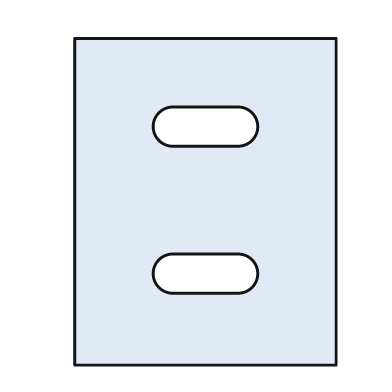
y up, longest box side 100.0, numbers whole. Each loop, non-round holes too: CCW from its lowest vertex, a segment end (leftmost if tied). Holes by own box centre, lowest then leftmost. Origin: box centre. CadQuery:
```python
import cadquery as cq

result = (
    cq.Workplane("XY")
    .moveTo(-40.0, -50.0)
    .lineTo(40.0, -50.0)
    .lineTo(40.0, 50.0)
    .lineTo(-40.0, 50.0)
    .close()
    .moveTo(-10.0, -28.0)
    .lineTo(10.0, -28.0)
    .threePointArc((16.0, -22.0), (10.0, -16.0))
    .lineTo(-10.0, -16.0)
    .threePointArc((-16.0, -22.0), (-10.0, -28.0))
    .close()
    .moveTo(-10.0, 17.0)
    .lineTo(10.0, 17.0)
    .threePointArc((16.0, 23.0), (10.0, 29.0))
    .lineTo(-10.0, 29.0)
    .threePointArc((-16.0, 23.0), (-10.0, 17.0))
    .close()
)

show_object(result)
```